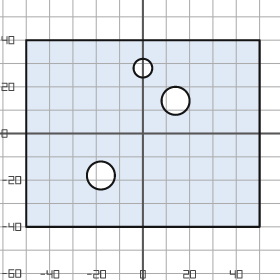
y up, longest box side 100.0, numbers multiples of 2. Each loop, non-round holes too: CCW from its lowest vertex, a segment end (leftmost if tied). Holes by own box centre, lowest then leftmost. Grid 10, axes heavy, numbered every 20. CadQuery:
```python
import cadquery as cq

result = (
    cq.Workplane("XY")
    .moveTo(-50.0, -40.0)
    .lineTo(50.0, -40.0)
    .lineTo(50.0, 40.0)
    .lineTo(-50.0, 40.0)
    .close()
    .moveTo(-18.0, -18.0)
    .circle(6.0)
    .moveTo(14.0, 14.0)
    .circle(6.0)
    .moveTo(0.0, 28.0)
    .circle(4.0)
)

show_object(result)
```